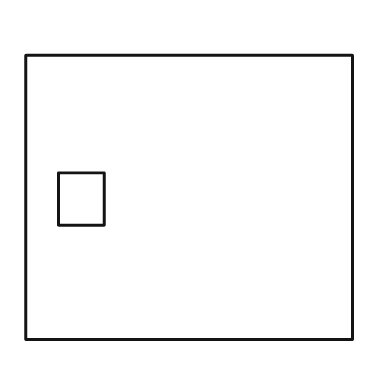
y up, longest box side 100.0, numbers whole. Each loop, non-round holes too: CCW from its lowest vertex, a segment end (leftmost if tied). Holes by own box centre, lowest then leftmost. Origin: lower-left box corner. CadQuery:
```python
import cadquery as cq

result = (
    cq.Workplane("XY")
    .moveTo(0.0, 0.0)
    .lineTo(100.0, 0.0)
    .lineTo(100.0, 87.0)
    .lineTo(0.0, 87.0)
    .close()
    .moveTo(10.0, 35.0)
    .lineTo(24.0, 35.0)
    .lineTo(24.0, 51.0)
    .lineTo(10.0, 51.0)
    .close()
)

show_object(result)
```